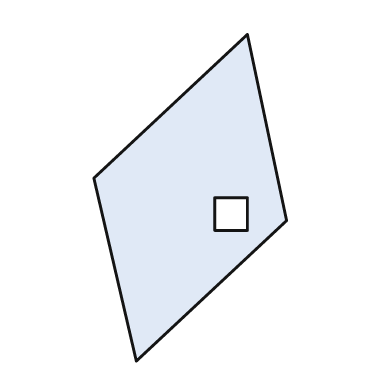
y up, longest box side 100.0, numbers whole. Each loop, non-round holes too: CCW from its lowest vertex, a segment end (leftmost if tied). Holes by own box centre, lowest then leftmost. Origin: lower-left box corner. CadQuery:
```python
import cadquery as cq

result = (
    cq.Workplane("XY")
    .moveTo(13.0, 0.0)
    .lineTo(59.0, 43.0)
    .lineTo(47.0, 100.0)
    .lineTo(0.0, 56.0)
    .close()
    .moveTo(37.0, 40.0)
    .lineTo(47.0, 40.0)
    .lineTo(47.0, 50.0)
    .lineTo(37.0, 50.0)
    .close()
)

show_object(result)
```